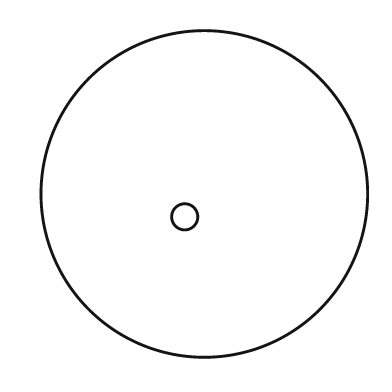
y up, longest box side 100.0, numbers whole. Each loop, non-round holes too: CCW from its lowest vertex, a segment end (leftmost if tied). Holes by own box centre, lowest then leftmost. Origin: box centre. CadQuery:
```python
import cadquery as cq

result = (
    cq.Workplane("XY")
    .moveTo(0.0, 0.0)
    .circle(50.0)
    .moveTo(-6.0, -7.0)
    .circle(4.0)
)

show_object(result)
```